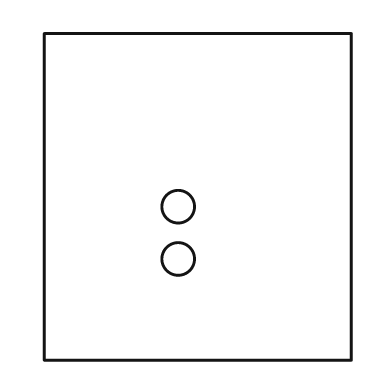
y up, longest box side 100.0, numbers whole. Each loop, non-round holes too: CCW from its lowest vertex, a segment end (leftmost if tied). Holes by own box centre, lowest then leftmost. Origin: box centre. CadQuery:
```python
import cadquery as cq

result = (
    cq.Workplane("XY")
    .moveTo(-47.0, -50.0)
    .lineTo(47.0, -50.0)
    .lineTo(47.0, 50.0)
    .lineTo(-47.0, 50.0)
    .close()
    .moveTo(-6.0, -19.0)
    .circle(5.0)
    .moveTo(-6.0, -3.0)
    .circle(5.0)
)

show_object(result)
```